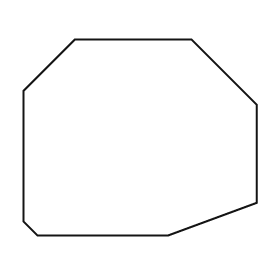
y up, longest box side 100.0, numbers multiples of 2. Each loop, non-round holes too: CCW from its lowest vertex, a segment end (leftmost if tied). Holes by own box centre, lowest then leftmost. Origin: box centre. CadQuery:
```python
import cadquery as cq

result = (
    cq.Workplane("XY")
    .moveTo(-44.0, -42.0)
    .lineTo(12.0, -42.0)
    .lineTo(50.0, -28.0)
    .lineTo(50.0, 14.0)
    .lineTo(22.0, 42.0)
    .lineTo(-28.0, 42.0)
    .lineTo(-50.0, 20.0)
    .lineTo(-50.0, -36.0)
    .close()
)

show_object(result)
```